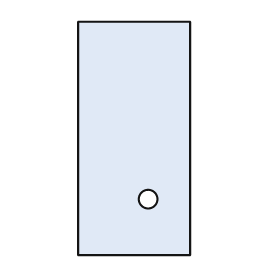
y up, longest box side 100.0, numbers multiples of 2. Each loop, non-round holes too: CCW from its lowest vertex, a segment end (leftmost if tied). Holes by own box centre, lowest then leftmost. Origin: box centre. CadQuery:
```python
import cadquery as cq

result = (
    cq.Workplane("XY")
    .moveTo(-24.0, -50.0)
    .lineTo(24.0, -50.0)
    .lineTo(24.0, 50.0)
    .lineTo(-24.0, 50.0)
    .close()
    .moveTo(6.0, -26.0)
    .circle(4.0)
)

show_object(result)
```